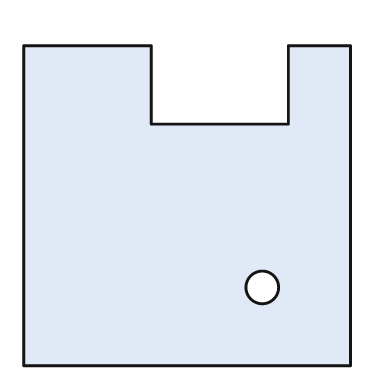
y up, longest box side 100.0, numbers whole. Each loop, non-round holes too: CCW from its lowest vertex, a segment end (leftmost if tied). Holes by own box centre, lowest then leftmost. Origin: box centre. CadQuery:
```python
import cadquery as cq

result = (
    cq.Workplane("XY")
    .moveTo(-50.0, -49.0)
    .lineTo(50.0, -49.0)
    .lineTo(50.0, 49.0)
    .lineTo(31.0, 49.0)
    .lineTo(31.0, 25.0)
    .lineTo(-11.0, 25.0)
    .lineTo(-11.0, 49.0)
    .lineTo(-50.0, 49.0)
    .close()
    .moveTo(23.0, -25.0)
    .circle(5.0)
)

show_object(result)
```